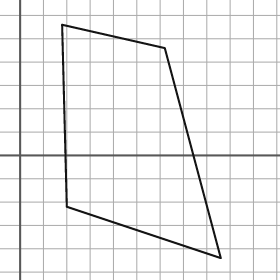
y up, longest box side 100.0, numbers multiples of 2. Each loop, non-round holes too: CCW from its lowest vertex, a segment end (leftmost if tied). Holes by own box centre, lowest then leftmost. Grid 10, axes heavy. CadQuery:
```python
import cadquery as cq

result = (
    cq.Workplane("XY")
    .moveTo(86.0, -44.0)
    .lineTo(62.0, 46.0)
    .lineTo(18.0, 56.0)
    .lineTo(20.0, -22.0)
    .close()
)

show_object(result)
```